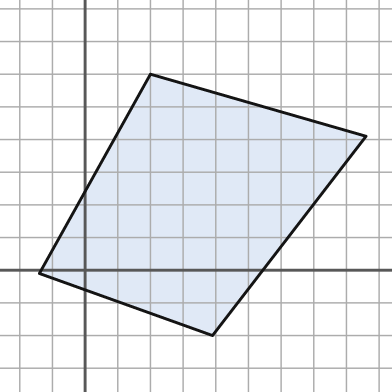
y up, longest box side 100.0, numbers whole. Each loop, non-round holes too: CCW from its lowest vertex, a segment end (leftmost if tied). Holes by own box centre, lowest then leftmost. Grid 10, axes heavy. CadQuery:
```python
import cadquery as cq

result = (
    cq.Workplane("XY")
    .moveTo(39.0, -20.0)
    .lineTo(86.0, 41.0)
    .lineTo(20.0, 60.0)
    .lineTo(-14.0, -1.0)
    .close()
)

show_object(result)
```